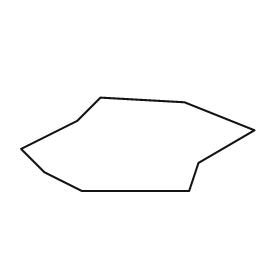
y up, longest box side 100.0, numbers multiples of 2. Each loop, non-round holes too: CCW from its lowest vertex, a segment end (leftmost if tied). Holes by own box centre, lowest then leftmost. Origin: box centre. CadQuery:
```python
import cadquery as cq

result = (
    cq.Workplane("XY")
    .moveTo(-24.0, -20.0)
    .lineTo(22.0, -20.0)
    .lineTo(26.0, -8.0)
    .lineTo(50.0, 6.0)
    .lineTo(20.0, 18.0)
    .lineTo(-16.0, 20.0)
    .lineTo(-26.0, 10.0)
    .lineTo(-50.0, -2.0)
    .lineTo(-40.0, -12.0)
    .close()
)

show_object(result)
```